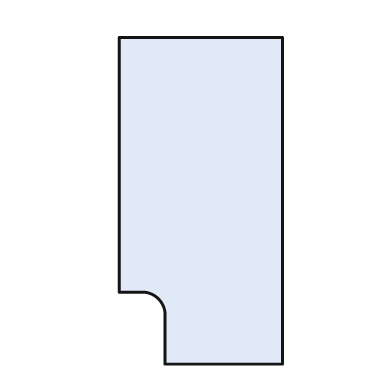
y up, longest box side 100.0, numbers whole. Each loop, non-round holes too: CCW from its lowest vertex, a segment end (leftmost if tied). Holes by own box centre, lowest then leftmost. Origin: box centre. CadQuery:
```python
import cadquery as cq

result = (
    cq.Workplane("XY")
    .moveTo(-11.0, -50.0)
    .lineTo(25.0, -50.0)
    .lineTo(25.0, 50.0)
    .lineTo(-25.0, 50.0)
    .lineTo(-25.0, -28.0)
    .lineTo(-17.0, -28.0)
    .threePointArc((-13.0, -30.0), (-11.0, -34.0))
    .close()
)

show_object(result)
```